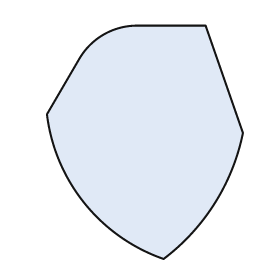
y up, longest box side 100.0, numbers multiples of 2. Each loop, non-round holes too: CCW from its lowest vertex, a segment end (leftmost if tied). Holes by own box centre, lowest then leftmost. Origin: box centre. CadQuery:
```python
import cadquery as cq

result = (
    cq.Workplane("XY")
    .moveTo(8.0, -50.0)
    .threePointArc((30.0, -26.0), (42.0, 4.0))
    .lineTo(26.0, 50.0)
    .lineTo(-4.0, 50.0)
    .threePointArc((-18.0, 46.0), (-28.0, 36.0))
    .lineTo(-42.0, 12.0)
    .threePointArc((-26.0, -26.0), (8.0, -50.0))
    .close()
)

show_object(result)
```